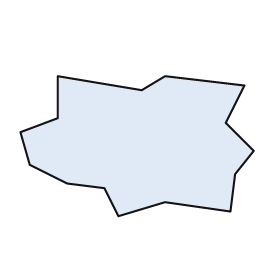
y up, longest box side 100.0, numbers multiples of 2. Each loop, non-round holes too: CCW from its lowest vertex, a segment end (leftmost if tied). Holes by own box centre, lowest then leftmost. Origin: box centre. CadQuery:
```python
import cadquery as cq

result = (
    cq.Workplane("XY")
    .moveTo(-8.0, -30.0)
    .lineTo(12.0, -24.0)
    .lineTo(40.0, -28.0)
    .lineTo(42.0, -12.0)
    .lineTo(50.0, -2.0)
    .lineTo(38.0, 10.0)
    .lineTo(46.0, 26.0)
    .lineTo(12.0, 30.0)
    .lineTo(2.0, 24.0)
    .lineTo(-34.0, 30.0)
    .lineTo(-34.0, 12.0)
    .lineTo(-50.0, 6.0)
    .lineTo(-46.0, -8.0)
    .lineTo(-30.0, -16.0)
    .lineTo(-14.0, -18.0)
    .close()
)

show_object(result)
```